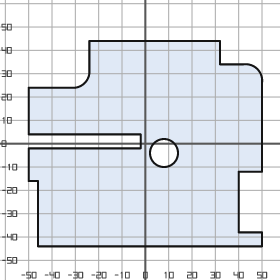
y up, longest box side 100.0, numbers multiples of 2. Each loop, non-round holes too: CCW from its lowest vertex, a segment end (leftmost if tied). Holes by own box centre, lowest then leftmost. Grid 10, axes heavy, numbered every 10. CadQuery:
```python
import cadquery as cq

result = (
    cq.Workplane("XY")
    .moveTo(-46.0, -44.0)
    .lineTo(50.0, -44.0)
    .lineTo(50.0, -38.0)
    .lineTo(40.0, -38.0)
    .lineTo(40.0, -12.0)
    .lineTo(50.0, -12.0)
    .lineTo(50.0, 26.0)
    .threePointArc((48.0, 32.0), (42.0, 34.0))
    .lineTo(32.0, 34.0)
    .lineTo(32.0, 44.0)
    .lineTo(-24.0, 44.0)
    .lineTo(-24.0, 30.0)
    .threePointArc((-26.0, 26.0), (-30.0, 24.0))
    .lineTo(-50.0, 24.0)
    .lineTo(-50.0, 4.0)
    .lineTo(-2.0, 4.0)
    .lineTo(-2.0, -2.0)
    .lineTo(-50.0, -2.0)
    .lineTo(-50.0, -16.0)
    .lineTo(-46.0, -16.0)
    .close()
    .moveTo(8.0, -4.0)
    .circle(6.0)
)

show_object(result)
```